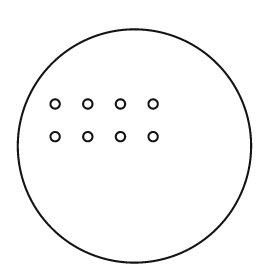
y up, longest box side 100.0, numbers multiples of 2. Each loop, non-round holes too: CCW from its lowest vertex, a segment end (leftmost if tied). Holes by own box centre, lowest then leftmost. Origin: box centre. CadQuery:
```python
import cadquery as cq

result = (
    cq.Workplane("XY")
    .moveTo(0.0, 0.0)
    .circle(50.0)
    .moveTo(-34.0, 4.0)
    .circle(2.0)
    .moveTo(-20.0, 4.0)
    .circle(2.0)
    .moveTo(-6.0, 4.0)
    .circle(2.0)
    .moveTo(8.0, 4.0)
    .circle(2.0)
    .moveTo(-34.0, 18.0)
    .circle(2.0)
    .moveTo(-20.0, 18.0)
    .circle(2.0)
    .moveTo(-6.0, 18.0)
    .circle(2.0)
    .moveTo(8.0, 18.0)
    .circle(2.0)
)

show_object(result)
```